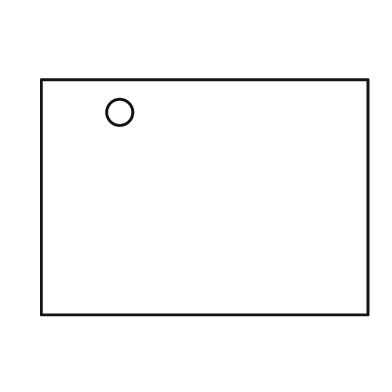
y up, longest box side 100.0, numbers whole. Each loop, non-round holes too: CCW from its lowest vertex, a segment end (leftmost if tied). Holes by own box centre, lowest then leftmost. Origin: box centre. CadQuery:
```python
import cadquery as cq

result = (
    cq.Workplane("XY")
    .moveTo(-50.0, -36.0)
    .lineTo(50.0, -36.0)
    .lineTo(50.0, 36.0)
    .lineTo(-50.0, 36.0)
    .close()
    .moveTo(-26.0, 26.0)
    .circle(4.0)
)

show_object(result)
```